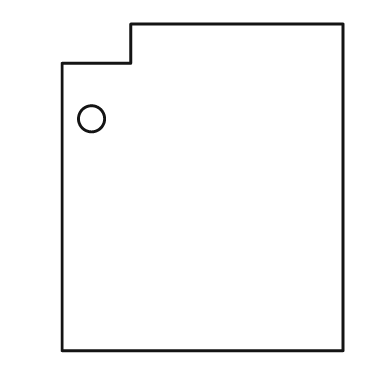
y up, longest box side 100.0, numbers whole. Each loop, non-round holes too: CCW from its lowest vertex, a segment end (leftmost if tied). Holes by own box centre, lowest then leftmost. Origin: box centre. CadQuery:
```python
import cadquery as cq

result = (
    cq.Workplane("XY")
    .moveTo(-43.0, -50.0)
    .lineTo(43.0, -50.0)
    .lineTo(43.0, 50.0)
    .lineTo(-22.0, 50.0)
    .lineTo(-22.0, 38.0)
    .lineTo(-43.0, 38.0)
    .close()
    .moveTo(-34.0, 21.0)
    .circle(4.0)
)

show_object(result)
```